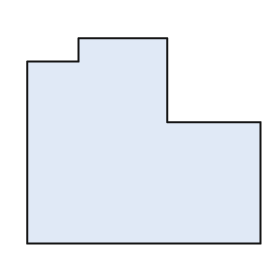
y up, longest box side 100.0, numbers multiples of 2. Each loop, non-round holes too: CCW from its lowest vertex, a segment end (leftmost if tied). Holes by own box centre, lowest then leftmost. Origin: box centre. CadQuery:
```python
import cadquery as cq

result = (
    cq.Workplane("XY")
    .moveTo(-50.0, -44.0)
    .lineTo(50.0, -44.0)
    .lineTo(50.0, 8.0)
    .lineTo(10.0, 8.0)
    .lineTo(10.0, 44.0)
    .lineTo(-28.0, 44.0)
    .lineTo(-28.0, 34.0)
    .lineTo(-50.0, 34.0)
    .close()
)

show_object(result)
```